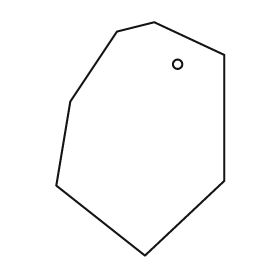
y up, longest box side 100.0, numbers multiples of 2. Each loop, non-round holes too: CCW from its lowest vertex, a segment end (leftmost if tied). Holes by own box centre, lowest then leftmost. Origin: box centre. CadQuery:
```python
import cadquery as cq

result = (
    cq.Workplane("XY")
    .moveTo(2.0, -50.0)
    .lineTo(36.0, -18.0)
    .lineTo(36.0, 36.0)
    .lineTo(6.0, 50.0)
    .lineTo(-10.0, 46.0)
    .lineTo(-30.0, 16.0)
    .lineTo(-36.0, -20.0)
    .close()
    .moveTo(16.0, 32.0)
    .circle(2.0)
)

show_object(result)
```